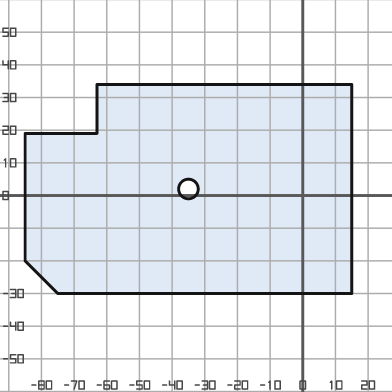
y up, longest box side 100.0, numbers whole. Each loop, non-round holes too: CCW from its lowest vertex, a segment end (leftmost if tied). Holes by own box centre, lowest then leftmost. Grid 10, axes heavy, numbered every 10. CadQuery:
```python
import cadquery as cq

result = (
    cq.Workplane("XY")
    .moveTo(-75.0, -30.0)
    .lineTo(15.0, -30.0)
    .lineTo(15.0, 34.0)
    .lineTo(-63.0, 34.0)
    .lineTo(-63.0, 19.0)
    .lineTo(-85.0, 19.0)
    .lineTo(-85.0, -20.0)
    .close()
    .moveTo(-35.0, 2.0)
    .circle(3.0)
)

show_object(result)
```